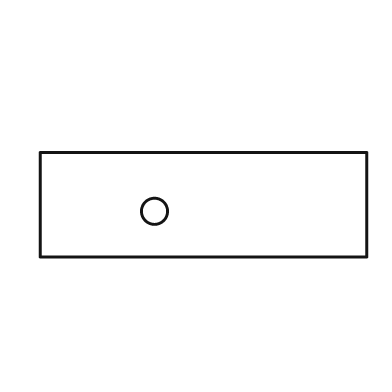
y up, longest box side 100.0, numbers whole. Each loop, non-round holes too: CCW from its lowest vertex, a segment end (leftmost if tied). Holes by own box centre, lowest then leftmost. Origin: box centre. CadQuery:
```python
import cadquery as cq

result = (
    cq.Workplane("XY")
    .moveTo(-50.0, -16.0)
    .lineTo(50.0, -16.0)
    .lineTo(50.0, 16.0)
    .lineTo(-50.0, 16.0)
    .close()
    .moveTo(-15.0, -2.0)
    .circle(4.0)
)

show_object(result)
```